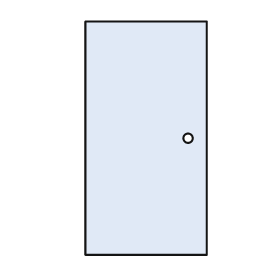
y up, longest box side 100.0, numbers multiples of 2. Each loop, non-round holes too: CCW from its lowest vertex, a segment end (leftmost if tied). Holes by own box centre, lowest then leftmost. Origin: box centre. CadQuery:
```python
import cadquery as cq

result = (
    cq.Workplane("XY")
    .moveTo(-26.0, -50.0)
    .lineTo(26.0, -50.0)
    .lineTo(26.0, 50.0)
    .lineTo(-26.0, 50.0)
    .close()
    .moveTo(18.0, 0.0)
    .circle(2.0)
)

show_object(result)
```